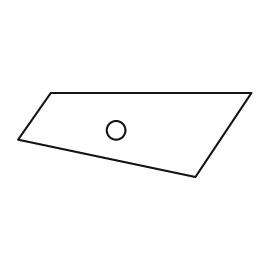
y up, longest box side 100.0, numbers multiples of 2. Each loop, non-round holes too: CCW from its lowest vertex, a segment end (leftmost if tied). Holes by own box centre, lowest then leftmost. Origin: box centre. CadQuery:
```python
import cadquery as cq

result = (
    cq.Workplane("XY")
    .moveTo(26.0, -18.0)
    .lineTo(50.0, 18.0)
    .lineTo(-36.0, 18.0)
    .lineTo(-50.0, -2.0)
    .close()
    .moveTo(-8.0, 2.0)
    .circle(4.0)
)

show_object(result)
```